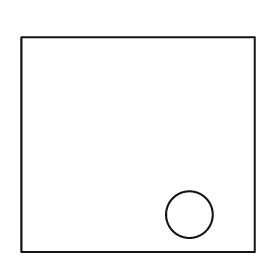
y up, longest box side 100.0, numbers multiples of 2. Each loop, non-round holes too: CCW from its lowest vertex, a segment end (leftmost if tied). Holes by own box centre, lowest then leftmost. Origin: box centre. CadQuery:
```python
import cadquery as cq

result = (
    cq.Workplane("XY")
    .moveTo(-50.0, -46.0)
    .lineTo(50.0, -46.0)
    .lineTo(50.0, 46.0)
    .lineTo(-50.0, 46.0)
    .close()
    .moveTo(22.0, -30.0)
    .circle(10.0)
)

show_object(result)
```